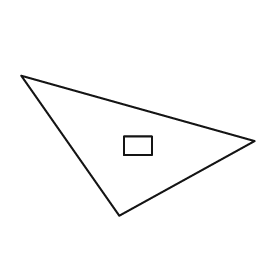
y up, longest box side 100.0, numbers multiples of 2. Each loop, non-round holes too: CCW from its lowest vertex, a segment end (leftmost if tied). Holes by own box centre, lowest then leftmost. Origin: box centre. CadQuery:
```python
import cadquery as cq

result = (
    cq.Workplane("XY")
    .moveTo(-8.0, -30.0)
    .lineTo(50.0, 2.0)
    .lineTo(-50.0, 30.0)
    .close()
    .moveTo(-6.0, -4.0)
    .lineTo(6.0, -4.0)
    .lineTo(6.0, 4.0)
    .lineTo(-6.0, 4.0)
    .close()
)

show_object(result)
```